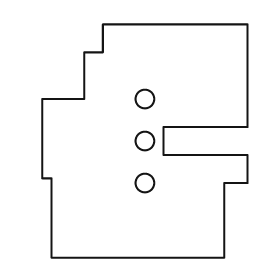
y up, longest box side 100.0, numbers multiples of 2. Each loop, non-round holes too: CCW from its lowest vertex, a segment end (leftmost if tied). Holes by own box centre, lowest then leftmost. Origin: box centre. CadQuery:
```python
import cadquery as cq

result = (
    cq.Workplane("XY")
    .moveTo(-40.0, -50.0)
    .lineTo(34.0, -50.0)
    .lineTo(34.0, -18.0)
    .lineTo(44.0, -18.0)
    .lineTo(44.0, -6.0)
    .lineTo(8.0, -6.0)
    .lineTo(8.0, 6.0)
    .lineTo(44.0, 6.0)
    .lineTo(44.0, 50.0)
    .lineTo(-18.0, 50.0)
    .lineTo(-18.0, 38.0)
    .lineTo(-26.0, 38.0)
    .lineTo(-26.0, 18.0)
    .lineTo(-44.0, 18.0)
    .lineTo(-44.0, -16.0)
    .lineTo(-40.0, -16.0)
    .close()
    .moveTo(0.0, -18.0)
    .circle(4.0)
    .moveTo(0.0, 0.0)
    .circle(4.0)
    .moveTo(0.0, 18.0)
    .circle(4.0)
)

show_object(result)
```